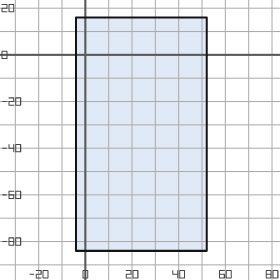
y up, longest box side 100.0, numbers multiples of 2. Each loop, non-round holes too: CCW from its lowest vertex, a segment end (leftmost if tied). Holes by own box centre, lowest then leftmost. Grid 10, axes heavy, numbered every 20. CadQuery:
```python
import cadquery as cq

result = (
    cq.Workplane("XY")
    .moveTo(-4.0, -84.0)
    .lineTo(52.0, -84.0)
    .lineTo(52.0, 16.0)
    .lineTo(-4.0, 16.0)
    .close()
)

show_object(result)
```